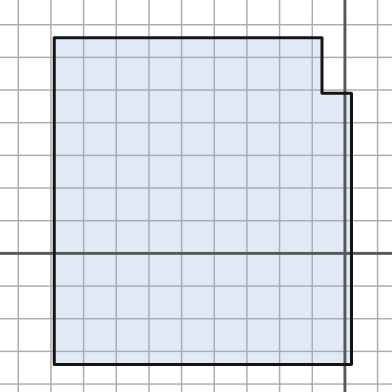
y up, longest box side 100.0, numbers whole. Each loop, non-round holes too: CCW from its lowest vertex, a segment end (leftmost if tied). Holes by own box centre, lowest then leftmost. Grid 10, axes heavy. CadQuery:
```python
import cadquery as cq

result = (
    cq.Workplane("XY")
    .moveTo(-89.0, -34.0)
    .lineTo(2.0, -34.0)
    .lineTo(2.0, 49.0)
    .lineTo(-7.0, 49.0)
    .lineTo(-7.0, 66.0)
    .lineTo(-89.0, 66.0)
    .close()
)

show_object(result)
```